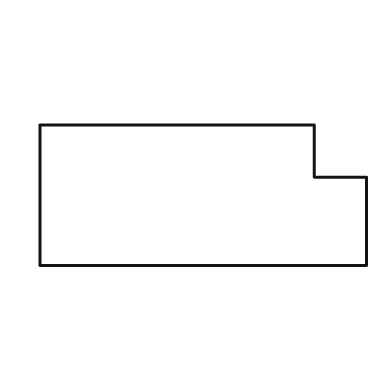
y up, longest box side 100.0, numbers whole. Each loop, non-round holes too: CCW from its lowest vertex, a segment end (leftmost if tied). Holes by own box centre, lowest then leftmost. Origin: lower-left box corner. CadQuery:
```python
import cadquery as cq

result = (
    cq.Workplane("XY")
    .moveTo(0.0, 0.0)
    .lineTo(100.0, 0.0)
    .lineTo(100.0, 27.0)
    .lineTo(84.0, 27.0)
    .lineTo(84.0, 43.0)
    .lineTo(0.0, 43.0)
    .close()
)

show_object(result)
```